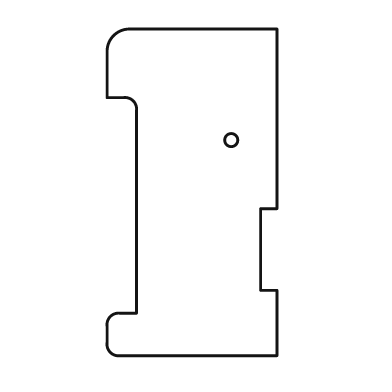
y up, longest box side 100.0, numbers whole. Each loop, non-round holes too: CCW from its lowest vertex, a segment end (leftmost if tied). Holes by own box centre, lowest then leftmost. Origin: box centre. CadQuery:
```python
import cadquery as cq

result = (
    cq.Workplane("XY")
    .moveTo(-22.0, -50.0)
    .lineTo(26.0, -50.0)
    .lineTo(26.0, -30.0)
    .lineTo(21.0, -30.0)
    .lineTo(21.0, -5.0)
    .lineTo(26.0, -5.0)
    .lineTo(26.0, 50.0)
    .lineTo(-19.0, 50.0)
    .threePointArc((-24.0, 48.0), (-26.0, 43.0))
    .lineTo(-26.0, 29.0)
    .lineTo(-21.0, 29.0)
    .threePointArc((-18.0, 28.0), (-17.0, 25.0))
    .lineTo(-17.0, -37.0)
    .lineTo(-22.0, -37.0)
    .threePointArc((-25.0, -38.0), (-26.0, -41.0))
    .lineTo(-26.0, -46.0)
    .threePointArc((-25.0, -49.0), (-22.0, -50.0))
    .close()
    .moveTo(12.0, 16.0)
    .circle(2.0)
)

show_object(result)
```